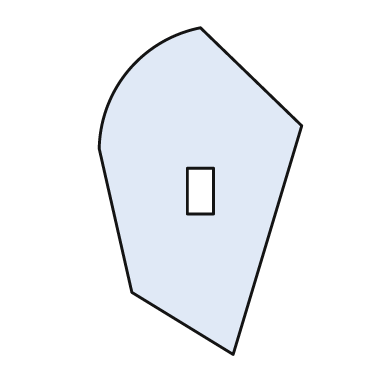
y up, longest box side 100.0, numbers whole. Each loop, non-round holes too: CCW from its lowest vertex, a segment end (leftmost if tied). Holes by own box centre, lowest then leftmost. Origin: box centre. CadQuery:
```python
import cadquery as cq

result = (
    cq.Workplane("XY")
    .moveTo(10.0, -50.0)
    .lineTo(31.0, 20.0)
    .lineTo(0.0, 50.0)
    .threePointArc((-22.0, 37.0), (-31.0, 13.0))
    .lineTo(-21.0, -31.0)
    .close()
    .moveTo(-4.0, -7.0)
    .lineTo(4.0, -7.0)
    .lineTo(4.0, 7.0)
    .lineTo(-4.0, 7.0)
    .close()
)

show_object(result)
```